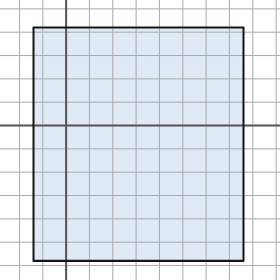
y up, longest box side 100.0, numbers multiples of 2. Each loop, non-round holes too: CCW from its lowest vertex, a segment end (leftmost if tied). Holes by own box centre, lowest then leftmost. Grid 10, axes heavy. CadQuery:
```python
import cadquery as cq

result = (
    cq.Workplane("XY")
    .moveTo(-14.0, -58.0)
    .lineTo(76.0, -58.0)
    .lineTo(76.0, 42.0)
    .lineTo(-14.0, 42.0)
    .close()
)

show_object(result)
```